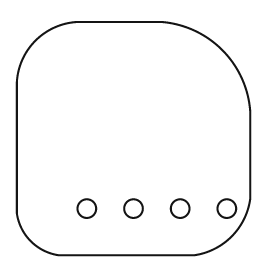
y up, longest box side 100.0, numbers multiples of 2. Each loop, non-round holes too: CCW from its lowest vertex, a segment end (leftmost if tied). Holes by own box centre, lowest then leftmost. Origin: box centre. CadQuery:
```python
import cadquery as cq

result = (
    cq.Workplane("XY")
    .moveTo(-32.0, -50.0)
    .lineTo(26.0, -50.0)
    .threePointArc((42.0, -42.0), (50.0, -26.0))
    .lineTo(50.0, 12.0)
    .threePointArc((38.0, 38.0), (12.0, 50.0))
    .lineTo(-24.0, 50.0)
    .threePointArc((-42.0, 42.0), (-50.0, 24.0))
    .lineTo(-50.0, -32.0)
    .threePointArc((-44.0, -44.0), (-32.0, -50.0))
    .close()
    .moveTo(-20.0, -30.0)
    .circle(4.0)
    .moveTo(0.0, -30.0)
    .circle(4.0)
    .moveTo(20.0, -30.0)
    .circle(4.0)
    .moveTo(40.0, -30.0)
    .circle(4.0)
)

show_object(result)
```